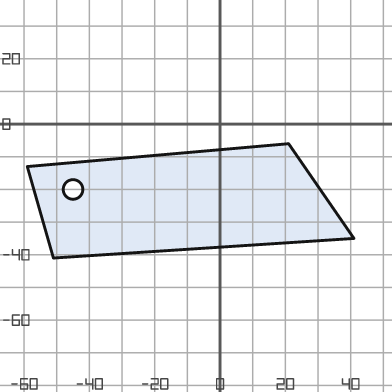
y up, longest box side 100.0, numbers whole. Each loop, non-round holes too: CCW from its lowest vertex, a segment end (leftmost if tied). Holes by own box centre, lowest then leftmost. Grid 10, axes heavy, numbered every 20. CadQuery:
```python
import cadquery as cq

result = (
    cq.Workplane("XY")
    .moveTo(-51.0, -41.0)
    .lineTo(41.0, -35.0)
    .lineTo(21.0, -6.0)
    .lineTo(-59.0, -13.0)
    .close()
    .moveTo(-45.0, -20.0)
    .circle(3.0)
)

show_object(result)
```